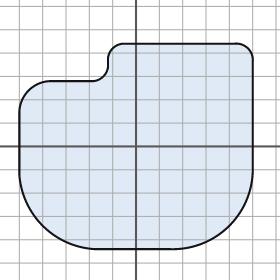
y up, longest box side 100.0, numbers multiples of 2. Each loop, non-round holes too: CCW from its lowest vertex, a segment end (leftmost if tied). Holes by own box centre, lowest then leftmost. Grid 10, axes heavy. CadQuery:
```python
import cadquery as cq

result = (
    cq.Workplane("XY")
    .moveTo(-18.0, -44.0)
    .lineTo(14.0, -44.0)
    .threePointArc((40.0, -34.0), (50.0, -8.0))
    .lineTo(50.0, 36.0)
    .threePointArc((48.0, 42.0), (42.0, 44.0))
    .lineTo(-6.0, 44.0)
    .threePointArc((-10.0, 42.0), (-12.0, 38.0))
    .lineTo(-12.0, 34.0)
    .threePointArc((-14.0, 30.0), (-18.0, 28.0))
    .lineTo(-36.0, 28.0)
    .threePointArc((-46.0, 24.0), (-50.0, 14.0))
    .lineTo(-50.0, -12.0)
    .threePointArc((-40.0, -34.0), (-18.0, -44.0))
    .close()
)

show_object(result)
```